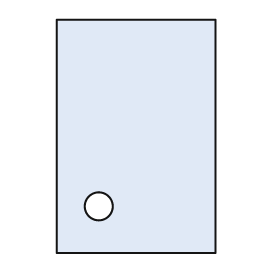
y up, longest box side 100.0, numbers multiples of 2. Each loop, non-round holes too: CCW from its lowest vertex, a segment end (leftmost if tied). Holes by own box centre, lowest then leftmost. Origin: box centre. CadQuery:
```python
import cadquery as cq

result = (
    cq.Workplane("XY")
    .moveTo(-34.0, -50.0)
    .lineTo(34.0, -50.0)
    .lineTo(34.0, 50.0)
    .lineTo(-34.0, 50.0)
    .close()
    .moveTo(-16.0, -30.0)
    .circle(6.0)
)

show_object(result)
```